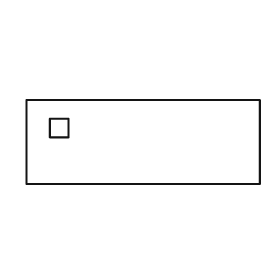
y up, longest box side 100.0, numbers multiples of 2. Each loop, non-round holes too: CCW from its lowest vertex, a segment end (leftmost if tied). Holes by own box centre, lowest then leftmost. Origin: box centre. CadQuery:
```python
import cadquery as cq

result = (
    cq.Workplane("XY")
    .moveTo(-50.0, -18.0)
    .lineTo(50.0, -18.0)
    .lineTo(50.0, 18.0)
    .lineTo(-50.0, 18.0)
    .close()
    .moveTo(-40.0, 2.0)
    .lineTo(-32.0, 2.0)
    .lineTo(-32.0, 10.0)
    .lineTo(-40.0, 10.0)
    .close()
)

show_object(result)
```